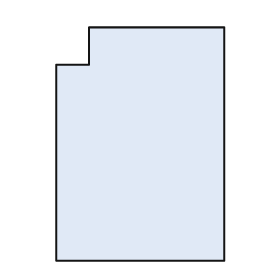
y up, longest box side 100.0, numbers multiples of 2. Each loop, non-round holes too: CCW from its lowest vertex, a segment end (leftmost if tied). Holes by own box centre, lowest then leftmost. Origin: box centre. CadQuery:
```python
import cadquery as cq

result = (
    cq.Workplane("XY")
    .moveTo(-36.0, -50.0)
    .lineTo(36.0, -50.0)
    .lineTo(36.0, 50.0)
    .lineTo(-22.0, 50.0)
    .lineTo(-22.0, 34.0)
    .lineTo(-36.0, 34.0)
    .close()
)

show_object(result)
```